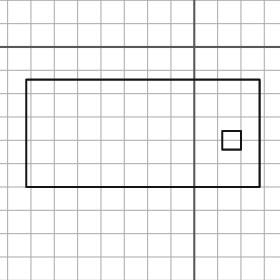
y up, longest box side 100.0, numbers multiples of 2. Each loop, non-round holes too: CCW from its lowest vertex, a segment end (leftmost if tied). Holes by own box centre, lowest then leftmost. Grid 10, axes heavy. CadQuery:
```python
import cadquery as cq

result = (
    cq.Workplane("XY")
    .moveTo(-72.0, -60.0)
    .lineTo(28.0, -60.0)
    .lineTo(28.0, -14.0)
    .lineTo(-72.0, -14.0)
    .close()
    .moveTo(12.0, -44.0)
    .lineTo(20.0, -44.0)
    .lineTo(20.0, -36.0)
    .lineTo(12.0, -36.0)
    .close()
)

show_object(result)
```